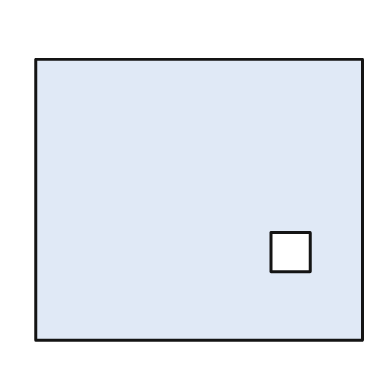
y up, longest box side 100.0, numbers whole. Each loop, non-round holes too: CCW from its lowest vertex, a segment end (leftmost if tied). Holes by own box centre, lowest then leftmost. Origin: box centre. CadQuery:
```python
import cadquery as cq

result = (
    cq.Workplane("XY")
    .moveTo(-50.0, -43.0)
    .lineTo(50.0, -43.0)
    .lineTo(50.0, 43.0)
    .lineTo(-50.0, 43.0)
    .close()
    .moveTo(22.0, -22.0)
    .lineTo(34.0, -22.0)
    .lineTo(34.0, -10.0)
    .lineTo(22.0, -10.0)
    .close()
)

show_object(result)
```